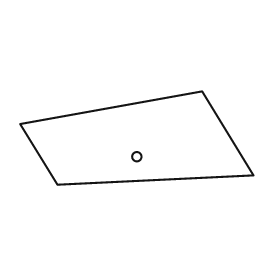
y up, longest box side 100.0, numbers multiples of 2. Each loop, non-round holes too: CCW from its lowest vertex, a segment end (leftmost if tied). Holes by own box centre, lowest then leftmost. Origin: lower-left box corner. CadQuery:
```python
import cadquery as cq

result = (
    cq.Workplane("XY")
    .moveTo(16.0, 0.0)
    .lineTo(100.0, 4.0)
    .lineTo(78.0, 40.0)
    .lineTo(0.0, 26.0)
    .close()
    .moveTo(50.0, 12.0)
    .circle(2.0)
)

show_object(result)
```